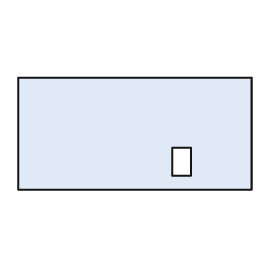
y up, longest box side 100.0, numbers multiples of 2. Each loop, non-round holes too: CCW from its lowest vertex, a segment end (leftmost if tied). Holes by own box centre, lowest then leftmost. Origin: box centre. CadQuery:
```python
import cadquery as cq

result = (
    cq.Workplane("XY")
    .moveTo(-50.0, -24.0)
    .lineTo(50.0, -24.0)
    .lineTo(50.0, 24.0)
    .lineTo(-50.0, 24.0)
    .close()
    .moveTo(16.0, -18.0)
    .lineTo(24.0, -18.0)
    .lineTo(24.0, -6.0)
    .lineTo(16.0, -6.0)
    .close()
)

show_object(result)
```